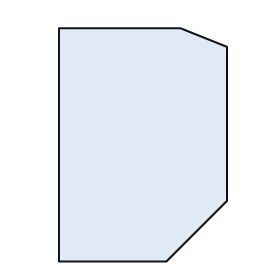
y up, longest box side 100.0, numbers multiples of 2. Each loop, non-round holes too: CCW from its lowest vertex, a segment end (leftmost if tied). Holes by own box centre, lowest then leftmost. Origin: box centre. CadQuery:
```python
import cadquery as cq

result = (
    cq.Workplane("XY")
    .moveTo(-36.0, -50.0)
    .lineTo(10.0, -50.0)
    .lineTo(36.0, -24.0)
    .lineTo(36.0, 42.0)
    .lineTo(16.0, 50.0)
    .lineTo(-36.0, 50.0)
    .close()
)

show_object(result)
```